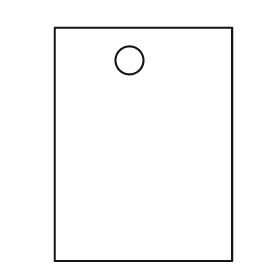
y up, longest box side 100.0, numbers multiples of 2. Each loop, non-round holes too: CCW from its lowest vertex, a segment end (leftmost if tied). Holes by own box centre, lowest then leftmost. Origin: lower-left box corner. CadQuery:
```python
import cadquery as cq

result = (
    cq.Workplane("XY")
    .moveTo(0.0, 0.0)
    .lineTo(76.0, 0.0)
    .lineTo(76.0, 100.0)
    .lineTo(0.0, 100.0)
    .close()
    .moveTo(32.0, 86.0)
    .circle(6.0)
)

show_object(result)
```